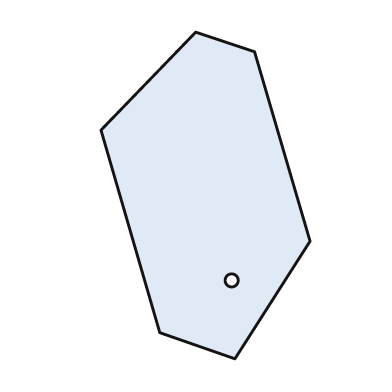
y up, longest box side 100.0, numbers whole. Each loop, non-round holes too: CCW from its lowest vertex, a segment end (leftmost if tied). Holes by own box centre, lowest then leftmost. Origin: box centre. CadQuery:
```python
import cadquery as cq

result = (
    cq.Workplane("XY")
    .moveTo(9.0, -50.0)
    .lineTo(32.0, -14.0)
    .lineTo(15.0, 44.0)
    .lineTo(-3.0, 50.0)
    .lineTo(-32.0, 20.0)
    .lineTo(-14.0, -42.0)
    .close()
    .moveTo(8.0, -26.0)
    .circle(2.0)
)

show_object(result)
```